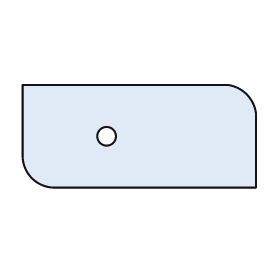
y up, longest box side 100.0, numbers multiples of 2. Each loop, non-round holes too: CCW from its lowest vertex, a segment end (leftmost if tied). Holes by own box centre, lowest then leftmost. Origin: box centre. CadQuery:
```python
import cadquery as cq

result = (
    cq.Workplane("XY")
    .moveTo(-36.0, -22.0)
    .lineTo(50.0, -22.0)
    .lineTo(50.0, 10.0)
    .threePointArc((46.0, 18.0), (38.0, 22.0))
    .lineTo(-50.0, 22.0)
    .lineTo(-50.0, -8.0)
    .threePointArc((-46.0, -18.0), (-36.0, -22.0))
    .close()
    .moveTo(-14.0, 0.0)
    .circle(4.0)
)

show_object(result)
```